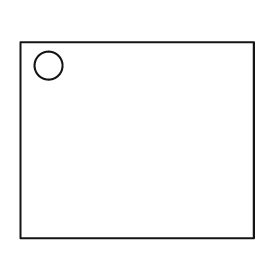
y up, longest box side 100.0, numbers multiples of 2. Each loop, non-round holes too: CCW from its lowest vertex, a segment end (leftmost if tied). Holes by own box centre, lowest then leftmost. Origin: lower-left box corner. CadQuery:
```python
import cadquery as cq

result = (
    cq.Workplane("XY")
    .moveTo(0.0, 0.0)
    .lineTo(100.0, 0.0)
    .lineTo(100.0, 84.0)
    .lineTo(0.0, 84.0)
    .close()
    .moveTo(12.0, 74.0)
    .circle(6.0)
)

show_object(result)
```